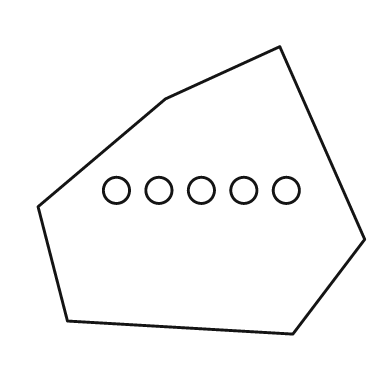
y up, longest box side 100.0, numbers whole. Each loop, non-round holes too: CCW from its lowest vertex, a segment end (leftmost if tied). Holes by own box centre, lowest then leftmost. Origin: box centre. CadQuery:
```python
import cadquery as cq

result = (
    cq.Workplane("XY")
    .moveTo(28.0, -44.0)
    .lineTo(50.0, -15.0)
    .lineTo(24.0, 44.0)
    .lineTo(-11.0, 28.0)
    .lineTo(-50.0, -5.0)
    .lineTo(-41.0, -40.0)
    .close()
    .moveTo(-26.0, 0.0)
    .circle(4.0)
    .moveTo(-13.0, 0.0)
    .circle(4.0)
    .moveTo(0.0, 0.0)
    .circle(4.0)
    .moveTo(13.0, 0.0)
    .circle(4.0)
    .moveTo(26.0, 0.0)
    .circle(4.0)
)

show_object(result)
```